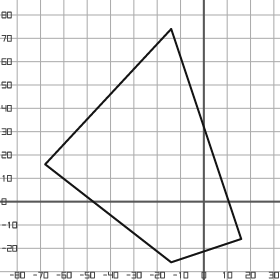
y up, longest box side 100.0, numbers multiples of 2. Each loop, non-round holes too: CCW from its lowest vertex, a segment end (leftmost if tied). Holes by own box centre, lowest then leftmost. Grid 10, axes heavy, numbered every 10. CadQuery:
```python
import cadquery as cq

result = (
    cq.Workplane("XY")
    .moveTo(-14.0, -26.0)
    .lineTo(16.0, -16.0)
    .lineTo(-14.0, 74.0)
    .lineTo(-68.0, 16.0)
    .close()
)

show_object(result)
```